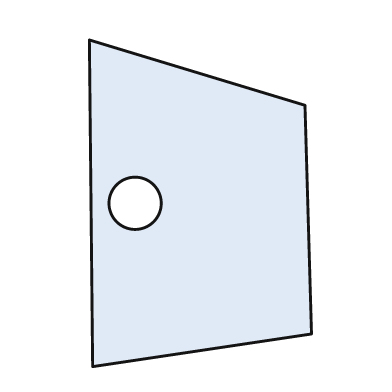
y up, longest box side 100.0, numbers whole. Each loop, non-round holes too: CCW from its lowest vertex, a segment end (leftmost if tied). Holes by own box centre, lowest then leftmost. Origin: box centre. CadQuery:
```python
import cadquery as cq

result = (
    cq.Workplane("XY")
    .moveTo(-33.0, -50.0)
    .lineTo(34.0, -40.0)
    .lineTo(32.0, 30.0)
    .lineTo(-34.0, 50.0)
    .close()
    .moveTo(-20.0, 0.0)
    .circle(8.0)
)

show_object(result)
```